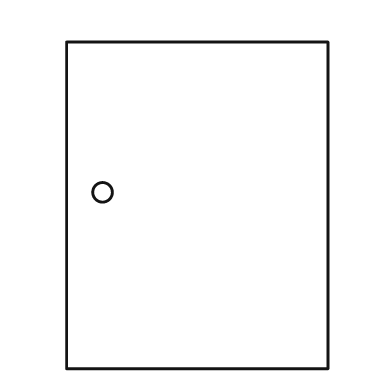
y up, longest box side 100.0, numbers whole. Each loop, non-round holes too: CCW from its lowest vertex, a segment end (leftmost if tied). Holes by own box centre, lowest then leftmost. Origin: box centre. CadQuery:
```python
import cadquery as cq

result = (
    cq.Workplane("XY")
    .moveTo(-40.0, -50.0)
    .lineTo(40.0, -50.0)
    .lineTo(40.0, 50.0)
    .lineTo(-40.0, 50.0)
    .close()
    .moveTo(-29.0, 4.0)
    .circle(3.0)
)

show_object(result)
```